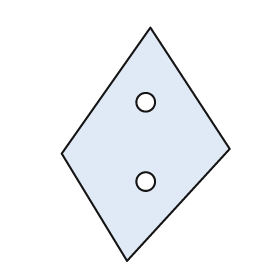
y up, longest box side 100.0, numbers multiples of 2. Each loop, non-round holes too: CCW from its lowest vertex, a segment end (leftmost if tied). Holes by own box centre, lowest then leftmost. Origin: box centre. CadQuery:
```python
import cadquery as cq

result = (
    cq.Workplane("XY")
    .moveTo(-8.0, -50.0)
    .lineTo(36.0, -2.0)
    .lineTo(2.0, 50.0)
    .lineTo(-36.0, -4.0)
    .close()
    .moveTo(0.0, -16.0)
    .circle(4.0)
    .moveTo(0.0, 18.0)
    .circle(4.0)
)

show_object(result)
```